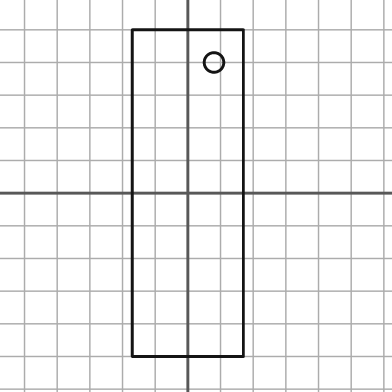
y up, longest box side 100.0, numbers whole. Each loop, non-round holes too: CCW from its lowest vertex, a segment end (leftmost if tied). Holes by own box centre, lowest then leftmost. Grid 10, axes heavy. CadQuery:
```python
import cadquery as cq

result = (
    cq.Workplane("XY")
    .moveTo(-17.0, -50.0)
    .lineTo(17.0, -50.0)
    .lineTo(17.0, 50.0)
    .lineTo(-17.0, 50.0)
    .close()
    .moveTo(8.0, 40.0)
    .circle(3.0)
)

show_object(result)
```